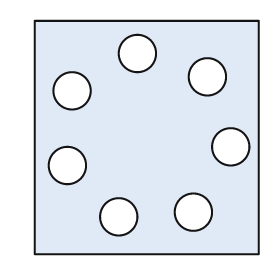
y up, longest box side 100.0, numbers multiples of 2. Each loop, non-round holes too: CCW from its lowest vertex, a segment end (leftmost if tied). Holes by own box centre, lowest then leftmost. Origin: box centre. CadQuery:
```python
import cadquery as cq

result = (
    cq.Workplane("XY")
    .moveTo(-48.0, -50.0)
    .lineTo(48.0, -50.0)
    .lineTo(48.0, 50.0)
    .lineTo(-48.0, 50.0)
    .close()
    .moveTo(-12.0, -34.0)
    .circle(8.0)
    .moveTo(20.0, -32.0)
    .circle(8.0)
    .moveTo(-34.0, -12.0)
    .circle(8.0)
    .moveTo(36.0, -4.0)
    .circle(8.0)
    .moveTo(-32.0, 20.0)
    .circle(8.0)
    .moveTo(26.0, 26.0)
    .circle(8.0)
    .moveTo(-4.0, 36.0)
    .circle(8.0)
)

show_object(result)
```